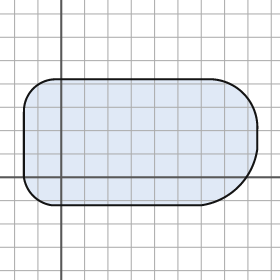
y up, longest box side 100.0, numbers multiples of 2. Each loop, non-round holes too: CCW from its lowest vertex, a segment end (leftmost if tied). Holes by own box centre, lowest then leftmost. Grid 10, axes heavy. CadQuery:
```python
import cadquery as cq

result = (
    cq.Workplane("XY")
    .moveTo(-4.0, -12.0)
    .lineTo(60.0, -12.0)
    .threePointArc((76.0, -4.0), (84.0, 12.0))
    .lineTo(84.0, 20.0)
    .threePointArc((78.0, 36.0), (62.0, 42.0))
    .lineTo(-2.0, 42.0)
    .threePointArc((-12.0, 38.0), (-16.0, 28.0))
    .lineTo(-16.0, 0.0)
    .threePointArc((-12.0, -8.0), (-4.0, -12.0))
    .close()
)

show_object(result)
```